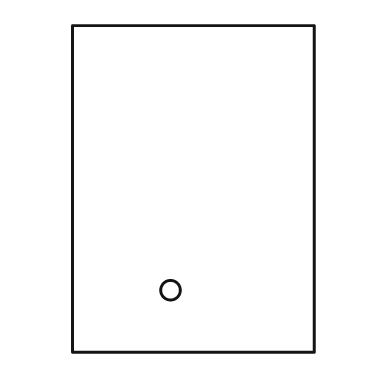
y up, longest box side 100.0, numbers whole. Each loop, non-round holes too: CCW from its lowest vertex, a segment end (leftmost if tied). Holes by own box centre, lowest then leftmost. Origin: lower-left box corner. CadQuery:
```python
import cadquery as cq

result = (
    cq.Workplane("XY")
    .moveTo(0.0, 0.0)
    .lineTo(74.0, 0.0)
    .lineTo(74.0, 100.0)
    .lineTo(0.0, 100.0)
    .close()
    .moveTo(30.0, 19.0)
    .circle(3.0)
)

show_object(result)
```